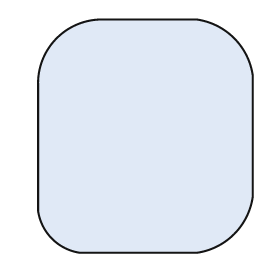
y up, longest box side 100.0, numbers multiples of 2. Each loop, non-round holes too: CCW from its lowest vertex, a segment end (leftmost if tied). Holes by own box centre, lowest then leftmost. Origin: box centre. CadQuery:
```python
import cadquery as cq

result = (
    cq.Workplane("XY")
    .moveTo(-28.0, -50.0)
    .lineTo(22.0, -50.0)
    .threePointArc((38.0, -42.0), (46.0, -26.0))
    .lineTo(46.0, 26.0)
    .threePointArc((38.0, 42.0), (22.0, 50.0))
    .lineTo(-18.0, 50.0)
    .threePointArc((-38.0, 42.0), (-46.0, 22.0))
    .lineTo(-46.0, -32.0)
    .threePointArc((-40.0, -44.0), (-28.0, -50.0))
    .close()
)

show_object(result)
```